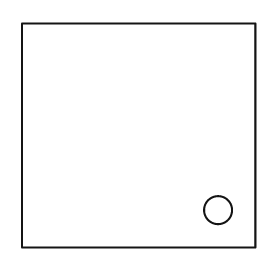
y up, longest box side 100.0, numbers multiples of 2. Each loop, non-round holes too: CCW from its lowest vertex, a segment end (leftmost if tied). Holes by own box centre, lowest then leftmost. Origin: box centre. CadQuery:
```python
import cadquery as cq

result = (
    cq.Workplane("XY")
    .moveTo(-50.0, -48.0)
    .lineTo(50.0, -48.0)
    .lineTo(50.0, 48.0)
    .lineTo(-50.0, 48.0)
    .close()
    .moveTo(34.0, -32.0)
    .circle(6.0)
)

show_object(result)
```